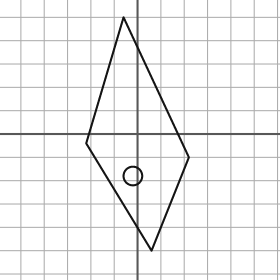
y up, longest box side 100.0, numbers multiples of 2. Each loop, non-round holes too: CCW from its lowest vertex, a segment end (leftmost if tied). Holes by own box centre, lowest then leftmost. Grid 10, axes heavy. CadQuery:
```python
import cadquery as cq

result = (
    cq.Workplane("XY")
    .moveTo(6.0, -50.0)
    .lineTo(22.0, -10.0)
    .lineTo(-6.0, 50.0)
    .lineTo(-22.0, -4.0)
    .close()
    .moveTo(-2.0, -18.0)
    .circle(4.0)
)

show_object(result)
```